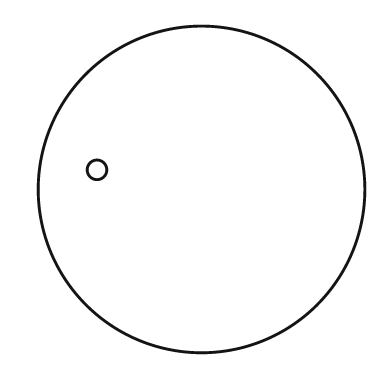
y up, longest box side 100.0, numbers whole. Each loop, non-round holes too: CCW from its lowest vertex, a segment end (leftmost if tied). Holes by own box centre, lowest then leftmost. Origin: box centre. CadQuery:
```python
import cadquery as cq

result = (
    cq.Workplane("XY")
    .moveTo(0.0, 0.0)
    .circle(50.0)
    .moveTo(-32.0, 6.0)
    .circle(3.0)
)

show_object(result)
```